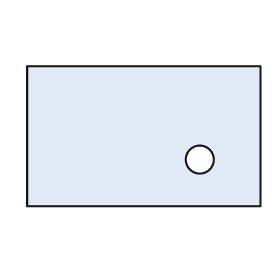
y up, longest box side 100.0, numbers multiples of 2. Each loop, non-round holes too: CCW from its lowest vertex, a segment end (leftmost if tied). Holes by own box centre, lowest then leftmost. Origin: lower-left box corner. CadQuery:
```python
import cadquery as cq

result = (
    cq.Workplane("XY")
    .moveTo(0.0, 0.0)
    .lineTo(100.0, 0.0)
    .lineTo(100.0, 60.0)
    .lineTo(0.0, 60.0)
    .close()
    .moveTo(74.0, 20.0)
    .circle(6.0)
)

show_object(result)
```